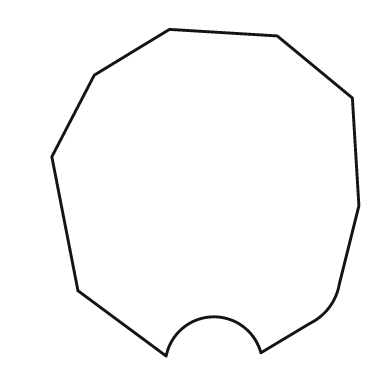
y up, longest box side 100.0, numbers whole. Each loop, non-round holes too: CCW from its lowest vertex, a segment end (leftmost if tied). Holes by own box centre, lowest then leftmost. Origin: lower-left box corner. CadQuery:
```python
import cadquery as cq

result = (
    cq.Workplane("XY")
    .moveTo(35.0, 0.0)
    .threePointArc((49.0, 12.0), (64.0, 1.0))
    .lineTo(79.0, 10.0)
    .threePointArc((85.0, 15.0), (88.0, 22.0))
    .lineTo(94.0, 46.0)
    .lineTo(92.0, 79.0)
    .lineTo(69.0, 98.0)
    .lineTo(36.0, 100.0)
    .lineTo(13.0, 86.0)
    .lineTo(0.0, 61.0)
    .lineTo(8.0, 20.0)
    .close()
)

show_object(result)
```